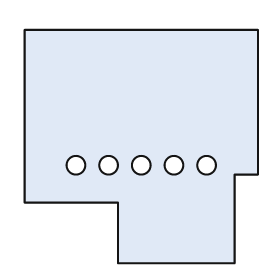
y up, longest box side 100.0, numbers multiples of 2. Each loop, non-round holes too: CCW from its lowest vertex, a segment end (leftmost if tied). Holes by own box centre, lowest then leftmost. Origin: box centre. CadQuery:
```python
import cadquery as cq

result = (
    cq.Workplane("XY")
    .moveTo(-10.0, -50.0)
    .lineTo(40.0, -50.0)
    .lineTo(40.0, -12.0)
    .lineTo(50.0, -12.0)
    .lineTo(50.0, 50.0)
    .lineTo(-50.0, 50.0)
    .lineTo(-50.0, -24.0)
    .lineTo(-10.0, -24.0)
    .close()
    .moveTo(-28.0, -8.0)
    .circle(4.0)
    .moveTo(-14.0, -8.0)
    .circle(4.0)
    .moveTo(0.0, -8.0)
    .circle(4.0)
    .moveTo(14.0, -8.0)
    .circle(4.0)
    .moveTo(28.0, -8.0)
    .circle(4.0)
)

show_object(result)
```